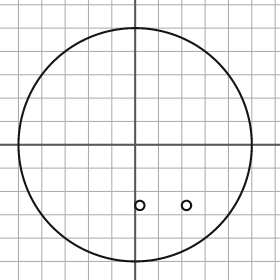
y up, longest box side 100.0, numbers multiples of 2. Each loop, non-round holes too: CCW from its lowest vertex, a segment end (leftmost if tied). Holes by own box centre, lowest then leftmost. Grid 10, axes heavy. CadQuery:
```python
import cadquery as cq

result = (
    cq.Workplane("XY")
    .moveTo(0.0, 0.0)
    .circle(50.0)
    .moveTo(2.0, -26.0)
    .circle(2.0)
    .moveTo(22.0, -26.0)
    .circle(2.0)
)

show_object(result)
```